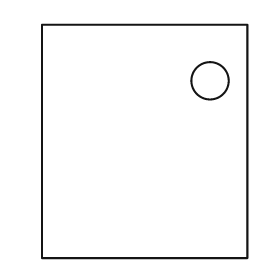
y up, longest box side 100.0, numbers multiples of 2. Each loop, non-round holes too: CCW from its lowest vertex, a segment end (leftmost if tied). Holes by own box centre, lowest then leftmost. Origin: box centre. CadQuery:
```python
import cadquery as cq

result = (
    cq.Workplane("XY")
    .moveTo(-44.0, -50.0)
    .lineTo(44.0, -50.0)
    .lineTo(44.0, 50.0)
    .lineTo(-44.0, 50.0)
    .close()
    .moveTo(28.0, 26.0)
    .circle(8.0)
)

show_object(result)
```